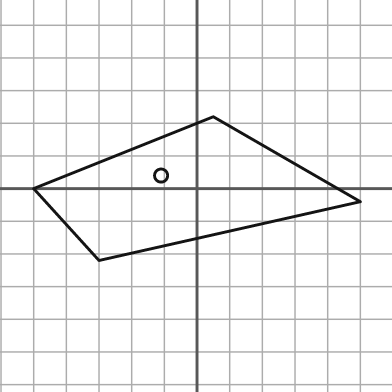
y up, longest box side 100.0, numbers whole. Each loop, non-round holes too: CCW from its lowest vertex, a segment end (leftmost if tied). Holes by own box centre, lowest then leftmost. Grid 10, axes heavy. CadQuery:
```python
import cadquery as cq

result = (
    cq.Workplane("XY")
    .moveTo(-30.0, -22.0)
    .lineTo(50.0, -4.0)
    .lineTo(5.0, 22.0)
    .lineTo(-50.0, 0.0)
    .close()
    .moveTo(-11.0, 4.0)
    .circle(2.0)
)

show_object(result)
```